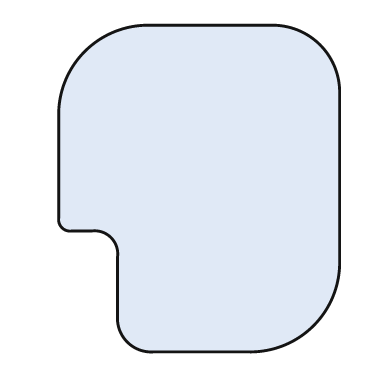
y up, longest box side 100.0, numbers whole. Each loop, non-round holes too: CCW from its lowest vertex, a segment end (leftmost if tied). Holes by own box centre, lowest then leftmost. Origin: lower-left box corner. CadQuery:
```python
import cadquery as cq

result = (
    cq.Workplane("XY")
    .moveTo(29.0, 0.0)
    .lineTo(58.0, 0.0)
    .threePointArc((78.0, 8.0), (86.0, 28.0))
    .lineTo(86.0, 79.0)
    .threePointArc((80.0, 94.0), (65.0, 100.0))
    .lineTo(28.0, 100.0)
    .threePointArc((8.0, 92.0), (0.0, 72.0))
    .lineTo(0.0, 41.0)
    .threePointArc((1.0, 38.0), (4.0, 37.0))
    .lineTo(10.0, 37.0)
    .threePointArc((16.0, 35.0), (18.0, 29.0))
    .lineTo(18.0, 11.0)
    .threePointArc((21.0, 3.0), (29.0, 0.0))
    .close()
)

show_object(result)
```